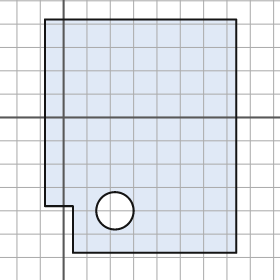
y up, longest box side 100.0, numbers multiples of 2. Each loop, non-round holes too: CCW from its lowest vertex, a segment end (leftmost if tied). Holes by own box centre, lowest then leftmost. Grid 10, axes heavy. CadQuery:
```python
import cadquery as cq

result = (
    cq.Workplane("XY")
    .moveTo(4.0, -58.0)
    .lineTo(74.0, -58.0)
    .lineTo(74.0, 42.0)
    .lineTo(-8.0, 42.0)
    .lineTo(-8.0, -38.0)
    .lineTo(4.0, -38.0)
    .close()
    .moveTo(22.0, -40.0)
    .circle(8.0)
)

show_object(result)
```